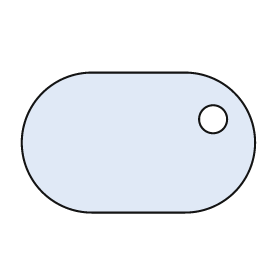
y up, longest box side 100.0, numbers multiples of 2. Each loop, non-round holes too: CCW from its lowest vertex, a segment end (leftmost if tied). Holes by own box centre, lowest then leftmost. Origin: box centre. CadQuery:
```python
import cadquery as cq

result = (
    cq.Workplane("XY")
    .moveTo(-20.0, -30.0)
    .lineTo(20.0, -30.0)
    .threePointArc((50.0, 0.0), (20.0, 30.0))
    .lineTo(-20.0, 30.0)
    .threePointArc((-50.0, 0.0), (-20.0, -30.0))
    .close()
    .moveTo(32.0, 10.0)
    .circle(6.0)
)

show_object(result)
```